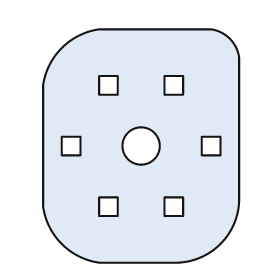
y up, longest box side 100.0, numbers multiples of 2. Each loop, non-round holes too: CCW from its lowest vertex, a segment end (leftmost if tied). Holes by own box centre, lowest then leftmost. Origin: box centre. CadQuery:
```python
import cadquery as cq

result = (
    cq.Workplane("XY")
    .moveTo(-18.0, -50.0)
    .lineTo(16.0, -50.0)
    .threePointArc((34.0, -42.0), (42.0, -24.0))
    .lineTo(42.0, 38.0)
    .threePointArc((38.0, 46.0), (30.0, 50.0))
    .lineTo(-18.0, 50.0)
    .threePointArc((-34.0, 42.0), (-42.0, 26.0))
    .lineTo(-42.0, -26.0)
    .threePointArc((-34.0, -42.0), (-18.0, -50.0))
    .close()
    .moveTo(-18.0, -30.0)
    .lineTo(-10.0, -30.0)
    .lineTo(-10.0, -22.0)
    .lineTo(-18.0, -22.0)
    .close()
    .moveTo(10.0, -30.0)
    .lineTo(18.0, -30.0)
    .lineTo(18.0, -22.0)
    .lineTo(10.0, -22.0)
    .close()
    .moveTo(-34.0, -4.0)
    .lineTo(-26.0, -4.0)
    .lineTo(-26.0, 4.0)
    .lineTo(-34.0, 4.0)
    .close()
    .moveTo(0.0, 0.0)
    .circle(8.0)
    .moveTo(26.0, -4.0)
    .lineTo(34.0, -4.0)
    .lineTo(34.0, 4.0)
    .lineTo(26.0, 4.0)
    .close()
    .moveTo(-18.0, 22.0)
    .lineTo(-10.0, 22.0)
    .lineTo(-10.0, 30.0)
    .lineTo(-18.0, 30.0)
    .close()
    .moveTo(10.0, 22.0)
    .lineTo(18.0, 22.0)
    .lineTo(18.0, 30.0)
    .lineTo(10.0, 30.0)
    .close()
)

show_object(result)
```